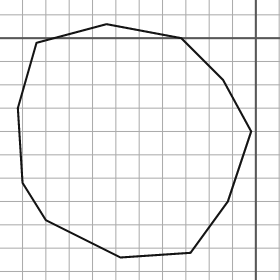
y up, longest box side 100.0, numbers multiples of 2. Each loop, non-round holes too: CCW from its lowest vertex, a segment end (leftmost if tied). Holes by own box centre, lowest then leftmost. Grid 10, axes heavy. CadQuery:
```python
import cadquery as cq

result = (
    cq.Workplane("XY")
    .moveTo(-58.0, -94.0)
    .lineTo(-28.0, -92.0)
    .lineTo(-12.0, -70.0)
    .lineTo(-2.0, -40.0)
    .lineTo(-14.0, -18.0)
    .lineTo(-32.0, 0.0)
    .lineTo(-64.0, 6.0)
    .lineTo(-94.0, -2.0)
    .lineTo(-102.0, -30.0)
    .lineTo(-100.0, -62.0)
    .lineTo(-90.0, -78.0)
    .close()
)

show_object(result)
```